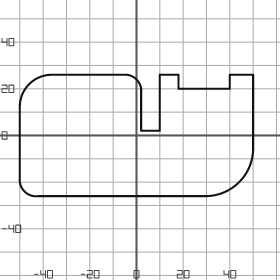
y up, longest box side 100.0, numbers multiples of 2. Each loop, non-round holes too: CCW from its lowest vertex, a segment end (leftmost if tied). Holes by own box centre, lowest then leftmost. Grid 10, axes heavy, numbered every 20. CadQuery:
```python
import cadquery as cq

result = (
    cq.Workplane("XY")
    .moveTo(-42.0, -26.0)
    .lineTo(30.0, -26.0)
    .threePointArc((44.0, -20.0), (50.0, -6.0))
    .lineTo(50.0, 26.0)
    .lineTo(40.0, 26.0)
    .lineTo(40.0, 20.0)
    .lineTo(18.0, 20.0)
    .lineTo(18.0, 26.0)
    .lineTo(10.0, 26.0)
    .lineTo(10.0, 2.0)
    .lineTo(2.0, 2.0)
    .lineTo(2.0, 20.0)
    .threePointArc((0.0, 24.0), (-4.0, 26.0))
    .lineTo(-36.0, 26.0)
    .threePointArc((-46.0, 22.0), (-50.0, 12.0))
    .lineTo(-50.0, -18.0)
    .threePointArc((-48.0, -24.0), (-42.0, -26.0))
    .close()
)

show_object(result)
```